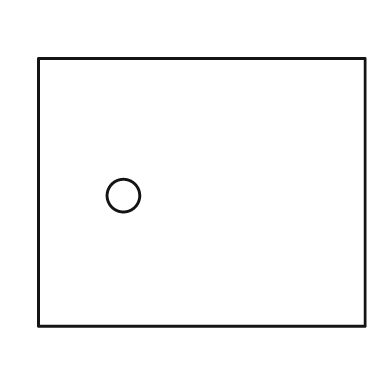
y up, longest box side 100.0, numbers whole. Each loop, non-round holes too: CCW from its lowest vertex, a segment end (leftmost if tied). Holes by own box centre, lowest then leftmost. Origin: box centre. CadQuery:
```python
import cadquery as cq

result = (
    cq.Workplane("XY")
    .moveTo(-50.0, -41.0)
    .lineTo(50.0, -41.0)
    .lineTo(50.0, 41.0)
    .lineTo(-50.0, 41.0)
    .close()
    .moveTo(-24.0, -1.0)
    .circle(5.0)
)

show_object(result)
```